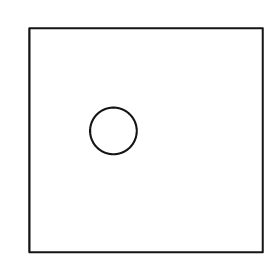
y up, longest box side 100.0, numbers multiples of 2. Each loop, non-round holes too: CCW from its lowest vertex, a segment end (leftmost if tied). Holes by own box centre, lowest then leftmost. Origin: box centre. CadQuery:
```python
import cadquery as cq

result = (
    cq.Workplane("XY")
    .moveTo(-50.0, -48.0)
    .lineTo(50.0, -48.0)
    .lineTo(50.0, 48.0)
    .lineTo(-50.0, 48.0)
    .close()
    .moveTo(-14.0, 4.0)
    .circle(10.0)
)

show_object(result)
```